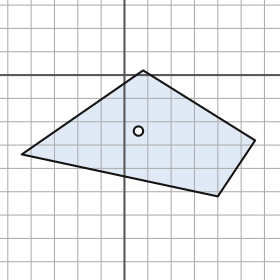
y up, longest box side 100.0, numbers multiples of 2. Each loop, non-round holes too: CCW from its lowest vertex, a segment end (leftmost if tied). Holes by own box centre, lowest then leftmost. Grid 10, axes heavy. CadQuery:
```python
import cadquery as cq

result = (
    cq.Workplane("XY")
    .moveTo(40.0, -52.0)
    .lineTo(56.0, -28.0)
    .lineTo(8.0, 2.0)
    .lineTo(-44.0, -34.0)
    .close()
    .moveTo(6.0, -24.0)
    .circle(2.0)
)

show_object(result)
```